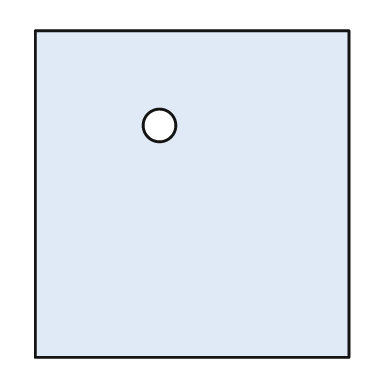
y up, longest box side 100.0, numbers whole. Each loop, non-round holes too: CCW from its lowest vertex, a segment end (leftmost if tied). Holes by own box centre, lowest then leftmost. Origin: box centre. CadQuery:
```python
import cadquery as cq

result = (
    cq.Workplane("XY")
    .moveTo(-48.0, -50.0)
    .lineTo(48.0, -50.0)
    .lineTo(48.0, 50.0)
    .lineTo(-48.0, 50.0)
    .close()
    .moveTo(-10.0, 21.0)
    .circle(5.0)
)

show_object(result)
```